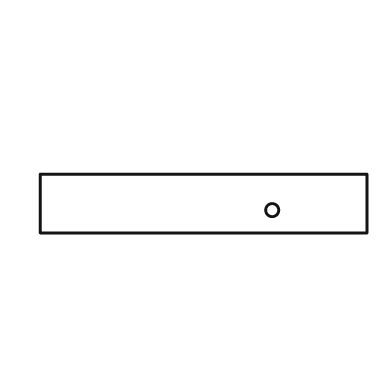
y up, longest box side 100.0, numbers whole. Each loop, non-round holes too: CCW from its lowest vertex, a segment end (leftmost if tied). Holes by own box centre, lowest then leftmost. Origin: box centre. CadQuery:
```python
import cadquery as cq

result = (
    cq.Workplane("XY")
    .moveTo(-50.0, -9.0)
    .lineTo(50.0, -9.0)
    .lineTo(50.0, 9.0)
    .lineTo(-50.0, 9.0)
    .close()
    .moveTo(21.0, -2.0)
    .circle(2.0)
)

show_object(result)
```